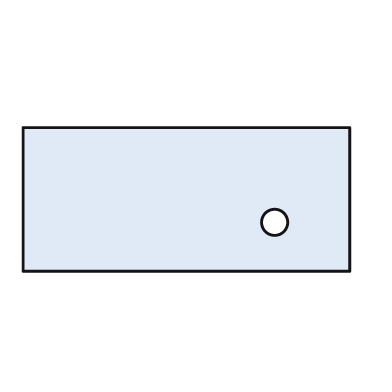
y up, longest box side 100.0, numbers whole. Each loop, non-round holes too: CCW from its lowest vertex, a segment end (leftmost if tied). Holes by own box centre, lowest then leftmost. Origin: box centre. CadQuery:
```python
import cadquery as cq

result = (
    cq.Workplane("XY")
    .moveTo(-50.0, -22.0)
    .lineTo(50.0, -22.0)
    .lineTo(50.0, 22.0)
    .lineTo(-50.0, 22.0)
    .close()
    .moveTo(27.0, -7.0)
    .circle(4.0)
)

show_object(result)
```